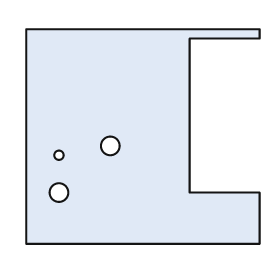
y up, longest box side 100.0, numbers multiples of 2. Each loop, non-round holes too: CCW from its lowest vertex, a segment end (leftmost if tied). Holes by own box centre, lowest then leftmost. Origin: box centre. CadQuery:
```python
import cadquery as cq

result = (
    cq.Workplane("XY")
    .moveTo(-50.0, -46.0)
    .lineTo(50.0, -46.0)
    .lineTo(50.0, -24.0)
    .lineTo(20.0, -24.0)
    .lineTo(20.0, 42.0)
    .lineTo(50.0, 42.0)
    .lineTo(50.0, 46.0)
    .lineTo(-50.0, 46.0)
    .close()
    .moveTo(-36.0, -24.0)
    .circle(4.0)
    .moveTo(-36.0, -8.0)
    .circle(2.0)
    .moveTo(-14.0, -4.0)
    .circle(4.0)
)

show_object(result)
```